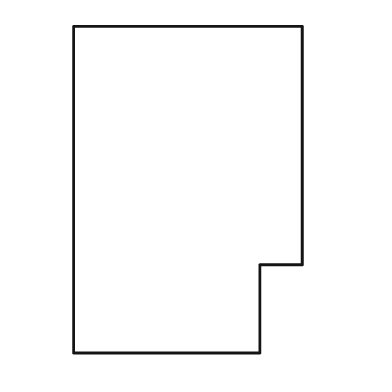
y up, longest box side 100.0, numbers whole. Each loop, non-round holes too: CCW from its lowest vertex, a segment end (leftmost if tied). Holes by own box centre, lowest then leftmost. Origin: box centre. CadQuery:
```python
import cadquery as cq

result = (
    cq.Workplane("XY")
    .moveTo(-35.0, -50.0)
    .lineTo(22.0, -50.0)
    .lineTo(22.0, -23.0)
    .lineTo(35.0, -23.0)
    .lineTo(35.0, 50.0)
    .lineTo(-35.0, 50.0)
    .close()
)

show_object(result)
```